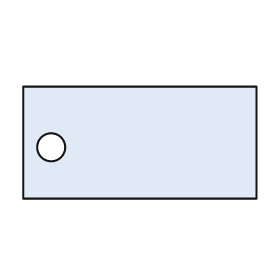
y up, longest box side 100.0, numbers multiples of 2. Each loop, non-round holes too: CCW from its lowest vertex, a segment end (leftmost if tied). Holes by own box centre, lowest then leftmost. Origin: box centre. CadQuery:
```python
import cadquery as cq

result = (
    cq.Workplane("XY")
    .moveTo(-50.0, -24.0)
    .lineTo(50.0, -24.0)
    .lineTo(50.0, 24.0)
    .lineTo(-50.0, 24.0)
    .close()
    .moveTo(-38.0, -2.0)
    .circle(6.0)
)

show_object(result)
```